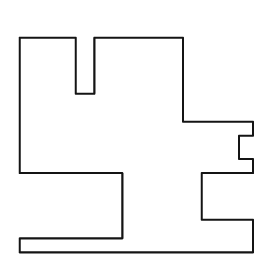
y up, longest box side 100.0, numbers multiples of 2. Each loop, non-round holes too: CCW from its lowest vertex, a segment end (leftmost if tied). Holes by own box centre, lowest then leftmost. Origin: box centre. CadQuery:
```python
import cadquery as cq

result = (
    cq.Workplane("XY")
    .moveTo(-50.0, -46.0)
    .lineTo(50.0, -46.0)
    .lineTo(50.0, -32.0)
    .lineTo(28.0, -32.0)
    .lineTo(28.0, -12.0)
    .lineTo(50.0, -12.0)
    .lineTo(50.0, -6.0)
    .lineTo(44.0, -6.0)
    .lineTo(44.0, 4.0)
    .lineTo(50.0, 4.0)
    .lineTo(50.0, 10.0)
    .lineTo(20.0, 10.0)
    .lineTo(20.0, 46.0)
    .lineTo(-18.0, 46.0)
    .lineTo(-18.0, 22.0)
    .lineTo(-26.0, 22.0)
    .lineTo(-26.0, 46.0)
    .lineTo(-50.0, 46.0)
    .lineTo(-50.0, -12.0)
    .lineTo(-6.0, -12.0)
    .lineTo(-6.0, -40.0)
    .lineTo(-50.0, -40.0)
    .close()
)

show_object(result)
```